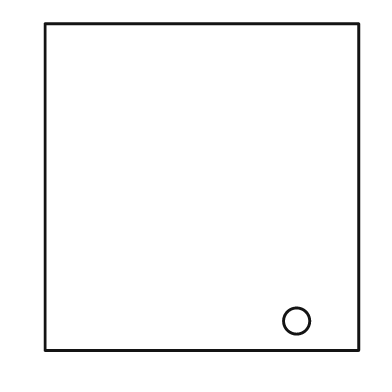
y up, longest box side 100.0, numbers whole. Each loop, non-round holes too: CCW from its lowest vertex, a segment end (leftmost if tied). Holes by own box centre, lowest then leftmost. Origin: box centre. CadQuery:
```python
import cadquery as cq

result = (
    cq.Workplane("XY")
    .moveTo(-48.0, -50.0)
    .lineTo(48.0, -50.0)
    .lineTo(48.0, 50.0)
    .lineTo(-48.0, 50.0)
    .close()
    .moveTo(29.0, -41.0)
    .circle(4.0)
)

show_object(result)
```